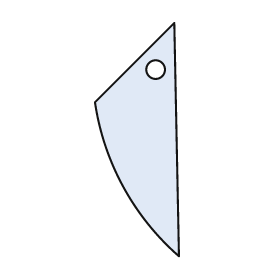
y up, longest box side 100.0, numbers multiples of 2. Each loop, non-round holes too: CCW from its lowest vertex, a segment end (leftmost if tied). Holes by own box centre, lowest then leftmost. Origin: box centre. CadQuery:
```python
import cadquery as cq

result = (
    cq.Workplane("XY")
    .moveTo(18.0, -50.0)
    .lineTo(16.0, 50.0)
    .lineTo(-18.0, 16.0)
    .threePointArc((-6.0, -20.0), (18.0, -50.0))
    .close()
    .moveTo(8.0, 30.0)
    .circle(4.0)
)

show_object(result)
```